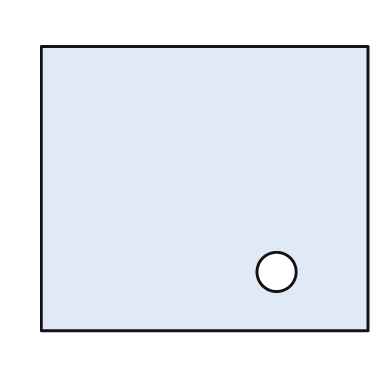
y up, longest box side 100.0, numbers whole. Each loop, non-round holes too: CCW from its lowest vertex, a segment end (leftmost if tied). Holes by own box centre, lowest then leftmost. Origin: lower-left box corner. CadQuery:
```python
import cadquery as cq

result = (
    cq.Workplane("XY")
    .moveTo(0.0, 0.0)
    .lineTo(100.0, 0.0)
    .lineTo(100.0, 87.0)
    .lineTo(0.0, 87.0)
    .close()
    .moveTo(72.0, 18.0)
    .circle(6.0)
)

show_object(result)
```